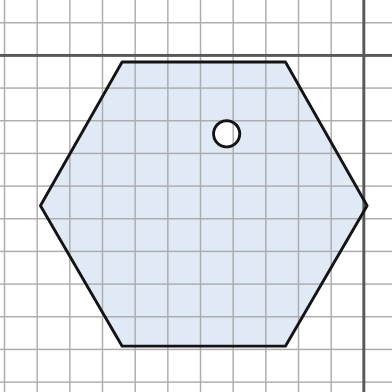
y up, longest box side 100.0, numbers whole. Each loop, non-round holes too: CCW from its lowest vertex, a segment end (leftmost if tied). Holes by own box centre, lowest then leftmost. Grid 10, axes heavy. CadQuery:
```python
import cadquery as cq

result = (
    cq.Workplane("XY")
    .moveTo(-74.0, -89.0)
    .lineTo(-24.0, -89.0)
    .lineTo(1.0, -46.0)
    .lineTo(-24.0, -2.0)
    .lineTo(-74.0, -2.0)
    .lineTo(-99.0, -46.0)
    .close()
    .moveTo(-42.0, -24.0)
    .circle(4.0)
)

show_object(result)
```